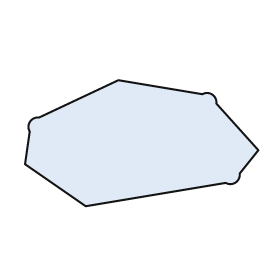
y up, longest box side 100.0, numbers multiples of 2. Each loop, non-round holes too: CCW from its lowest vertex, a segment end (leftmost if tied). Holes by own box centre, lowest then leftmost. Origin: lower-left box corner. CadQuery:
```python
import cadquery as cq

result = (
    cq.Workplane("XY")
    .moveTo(26.0, 0.0)
    .lineTo(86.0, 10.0)
    .threePointArc((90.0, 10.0), (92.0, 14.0))
    .lineTo(100.0, 24.0)
    .lineTo(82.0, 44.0)
    .threePointArc((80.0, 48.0), (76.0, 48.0))
    .lineTo(40.0, 54.0)
    .lineTo(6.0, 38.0)
    .threePointArc((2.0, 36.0), (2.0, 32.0))
    .lineTo(0.0, 18.0)
    .close()
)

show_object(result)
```